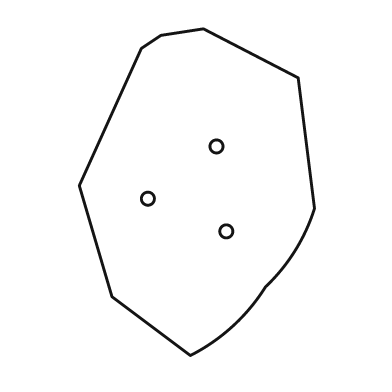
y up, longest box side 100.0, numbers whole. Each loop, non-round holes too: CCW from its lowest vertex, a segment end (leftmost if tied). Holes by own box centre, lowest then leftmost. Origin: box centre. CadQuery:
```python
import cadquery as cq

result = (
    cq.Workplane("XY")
    .moveTo(-2.0, -50.0)
    .threePointArc((11.0, -41.0), (21.0, -29.0))
    .threePointArc((30.0, -18.0), (36.0, -5.0))
    .lineTo(31.0, 35.0)
    .lineTo(2.0, 50.0)
    .lineTo(-11.0, 48.0)
    .lineTo(-17.0, 44.0)
    .lineTo(-36.0, 2.0)
    .lineTo(-26.0, -32.0)
    .close()
    .moveTo(9.0, -12.0)
    .circle(2.0)
    .moveTo(-15.0, -2.0)
    .circle(2.0)
    .moveTo(6.0, 14.0)
    .circle(2.0)
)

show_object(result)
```